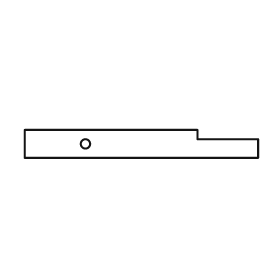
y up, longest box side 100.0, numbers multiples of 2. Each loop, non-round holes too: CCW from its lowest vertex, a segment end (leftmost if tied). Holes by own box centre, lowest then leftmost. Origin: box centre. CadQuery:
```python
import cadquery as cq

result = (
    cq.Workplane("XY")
    .moveTo(-50.0, -6.0)
    .lineTo(50.0, -6.0)
    .lineTo(50.0, 2.0)
    .lineTo(24.0, 2.0)
    .lineTo(24.0, 6.0)
    .lineTo(-50.0, 6.0)
    .close()
    .moveTo(-24.0, 0.0)
    .circle(2.0)
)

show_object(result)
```